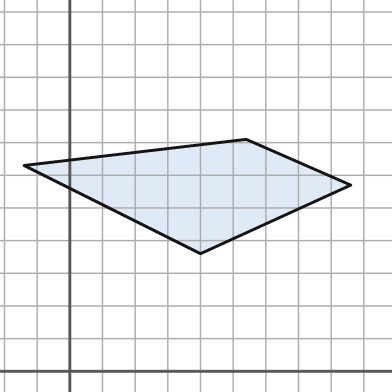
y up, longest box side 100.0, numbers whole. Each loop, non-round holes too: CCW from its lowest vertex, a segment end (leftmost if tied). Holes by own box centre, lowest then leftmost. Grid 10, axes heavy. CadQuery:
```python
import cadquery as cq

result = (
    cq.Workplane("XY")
    .moveTo(40.0, 36.0)
    .lineTo(86.0, 57.0)
    .lineTo(54.0, 71.0)
    .lineTo(-14.0, 63.0)
    .close()
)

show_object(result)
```